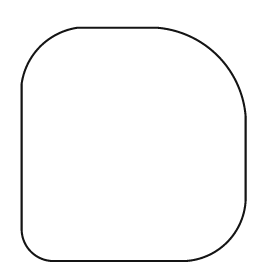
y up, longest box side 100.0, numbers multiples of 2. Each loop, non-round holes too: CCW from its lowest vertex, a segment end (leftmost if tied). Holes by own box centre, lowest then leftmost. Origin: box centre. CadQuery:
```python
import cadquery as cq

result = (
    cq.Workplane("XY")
    .moveTo(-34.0, -50.0)
    .lineTo(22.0, -50.0)
    .threePointArc((40.0, -42.0), (48.0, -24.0))
    .lineTo(48.0, 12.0)
    .threePointArc((36.0, 38.0), (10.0, 50.0))
    .lineTo(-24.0, 50.0)
    .threePointArc((-40.0, 42.0), (-48.0, 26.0))
    .lineTo(-48.0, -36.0)
    .threePointArc((-44.0, -46.0), (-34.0, -50.0))
    .close()
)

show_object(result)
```